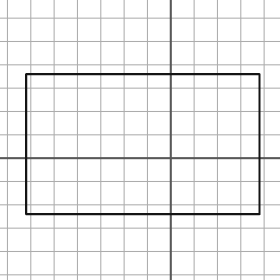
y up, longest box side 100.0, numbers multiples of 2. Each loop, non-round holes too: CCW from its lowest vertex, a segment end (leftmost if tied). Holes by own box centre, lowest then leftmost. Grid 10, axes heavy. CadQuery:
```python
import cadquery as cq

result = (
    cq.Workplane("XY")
    .moveTo(-62.0, -24.0)
    .lineTo(38.0, -24.0)
    .lineTo(38.0, 36.0)
    .lineTo(-62.0, 36.0)
    .close()
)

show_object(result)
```